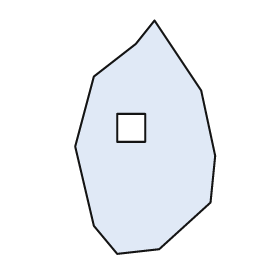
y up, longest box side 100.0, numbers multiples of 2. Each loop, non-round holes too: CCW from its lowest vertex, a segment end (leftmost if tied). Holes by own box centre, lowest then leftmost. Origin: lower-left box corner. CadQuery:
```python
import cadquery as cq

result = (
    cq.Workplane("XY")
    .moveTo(18.0, 0.0)
    .lineTo(36.0, 2.0)
    .lineTo(58.0, 22.0)
    .lineTo(60.0, 42.0)
    .lineTo(54.0, 70.0)
    .lineTo(34.0, 100.0)
    .lineTo(26.0, 90.0)
    .lineTo(8.0, 76.0)
    .lineTo(0.0, 46.0)
    .lineTo(8.0, 12.0)
    .close()
    .moveTo(18.0, 48.0)
    .lineTo(30.0, 48.0)
    .lineTo(30.0, 60.0)
    .lineTo(18.0, 60.0)
    .close()
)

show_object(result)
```